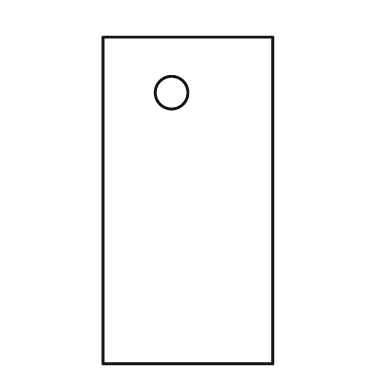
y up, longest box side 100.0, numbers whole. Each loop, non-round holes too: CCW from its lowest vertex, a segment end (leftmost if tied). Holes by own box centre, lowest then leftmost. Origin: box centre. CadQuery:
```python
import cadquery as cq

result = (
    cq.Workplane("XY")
    .moveTo(-26.0, -50.0)
    .lineTo(26.0, -50.0)
    .lineTo(26.0, 50.0)
    .lineTo(-26.0, 50.0)
    .close()
    .moveTo(-5.0, 33.0)
    .circle(5.0)
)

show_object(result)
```